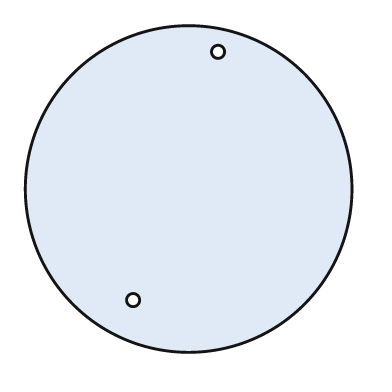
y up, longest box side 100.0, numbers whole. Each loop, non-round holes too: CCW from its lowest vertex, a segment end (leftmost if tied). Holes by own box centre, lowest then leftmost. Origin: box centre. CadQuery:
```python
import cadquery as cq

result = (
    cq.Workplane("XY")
    .moveTo(0.0, 0.0)
    .circle(50.0)
    .moveTo(-17.0, -34.0)
    .circle(2.0)
    .moveTo(9.0, 42.0)
    .circle(2.0)
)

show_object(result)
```